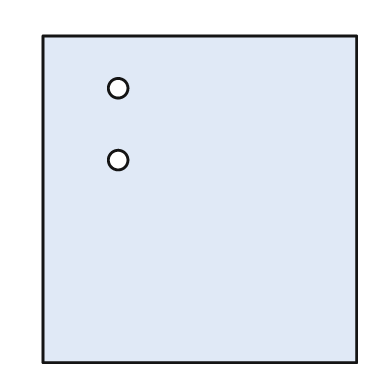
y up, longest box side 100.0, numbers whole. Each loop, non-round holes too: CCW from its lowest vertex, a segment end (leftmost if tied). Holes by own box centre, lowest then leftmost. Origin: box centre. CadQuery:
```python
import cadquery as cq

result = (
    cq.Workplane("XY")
    .moveTo(-48.0, -50.0)
    .lineTo(48.0, -50.0)
    .lineTo(48.0, 50.0)
    .lineTo(-48.0, 50.0)
    .close()
    .moveTo(-25.0, 12.0)
    .circle(3.0)
    .moveTo(-25.0, 34.0)
    .circle(3.0)
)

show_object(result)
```